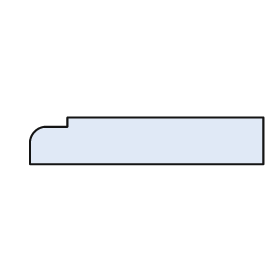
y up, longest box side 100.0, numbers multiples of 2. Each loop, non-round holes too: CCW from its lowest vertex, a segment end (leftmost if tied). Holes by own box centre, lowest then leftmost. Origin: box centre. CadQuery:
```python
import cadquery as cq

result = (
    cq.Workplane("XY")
    .moveTo(-50.0, -10.0)
    .lineTo(50.0, -10.0)
    .lineTo(50.0, 10.0)
    .lineTo(-34.0, 10.0)
    .lineTo(-34.0, 6.0)
    .lineTo(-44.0, 6.0)
    .threePointArc((-48.0, 4.0), (-50.0, 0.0))
    .close()
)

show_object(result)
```